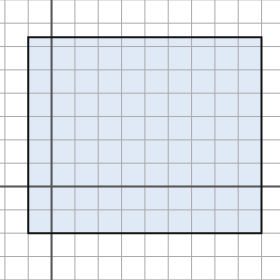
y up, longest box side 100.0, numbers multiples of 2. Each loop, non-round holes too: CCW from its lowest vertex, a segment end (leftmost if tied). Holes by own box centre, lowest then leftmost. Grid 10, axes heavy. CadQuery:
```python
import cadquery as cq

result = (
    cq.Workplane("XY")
    .moveTo(-10.0, -20.0)
    .lineTo(90.0, -20.0)
    .lineTo(90.0, 64.0)
    .lineTo(-10.0, 64.0)
    .close()
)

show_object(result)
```